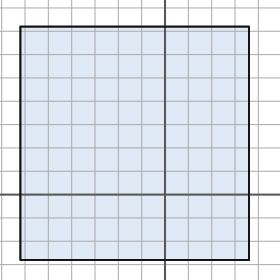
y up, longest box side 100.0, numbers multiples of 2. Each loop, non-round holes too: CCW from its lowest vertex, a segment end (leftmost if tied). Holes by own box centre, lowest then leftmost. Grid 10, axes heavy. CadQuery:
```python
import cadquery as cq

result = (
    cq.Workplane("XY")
    .moveTo(-62.0, -28.0)
    .lineTo(36.0, -28.0)
    .lineTo(36.0, 72.0)
    .lineTo(-62.0, 72.0)
    .close()
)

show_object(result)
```